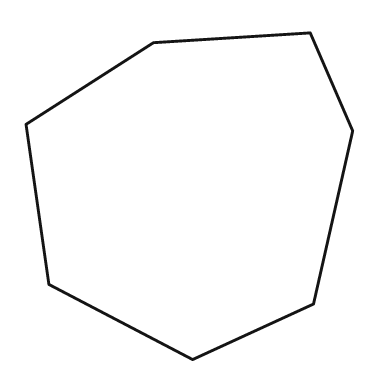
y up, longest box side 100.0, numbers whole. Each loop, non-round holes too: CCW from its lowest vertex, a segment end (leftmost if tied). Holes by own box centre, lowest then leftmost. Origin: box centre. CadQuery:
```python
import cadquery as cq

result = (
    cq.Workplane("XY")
    .moveTo(1.0, -50.0)
    .lineTo(38.0, -33.0)
    .lineTo(50.0, 20.0)
    .lineTo(37.0, 50.0)
    .lineTo(-11.0, 47.0)
    .lineTo(-50.0, 22.0)
    .lineTo(-43.0, -27.0)
    .close()
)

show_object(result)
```